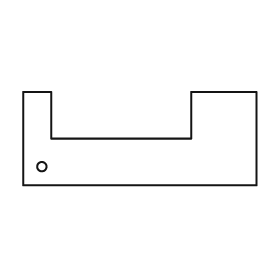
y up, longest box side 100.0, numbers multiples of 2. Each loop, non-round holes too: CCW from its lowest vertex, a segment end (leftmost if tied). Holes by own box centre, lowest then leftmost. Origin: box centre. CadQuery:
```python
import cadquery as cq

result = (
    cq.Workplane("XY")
    .moveTo(-50.0, -20.0)
    .lineTo(50.0, -20.0)
    .lineTo(50.0, 20.0)
    .lineTo(22.0, 20.0)
    .lineTo(22.0, 0.0)
    .lineTo(-38.0, 0.0)
    .lineTo(-38.0, 20.0)
    .lineTo(-50.0, 20.0)
    .close()
    .moveTo(-42.0, -12.0)
    .circle(2.0)
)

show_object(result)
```